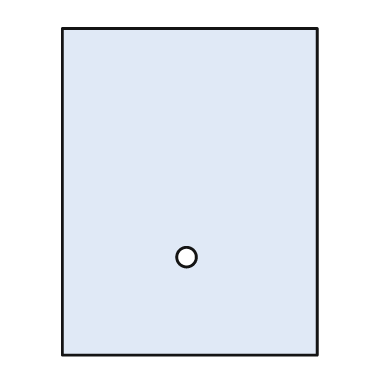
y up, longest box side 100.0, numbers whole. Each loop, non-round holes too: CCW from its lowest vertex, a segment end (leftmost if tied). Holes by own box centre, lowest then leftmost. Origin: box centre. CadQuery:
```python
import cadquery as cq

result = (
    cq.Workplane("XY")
    .moveTo(-39.0, -50.0)
    .lineTo(39.0, -50.0)
    .lineTo(39.0, 50.0)
    .lineTo(-39.0, 50.0)
    .close()
    .moveTo(-1.0, -20.0)
    .circle(3.0)
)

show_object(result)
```